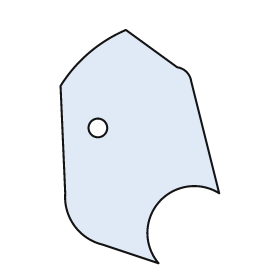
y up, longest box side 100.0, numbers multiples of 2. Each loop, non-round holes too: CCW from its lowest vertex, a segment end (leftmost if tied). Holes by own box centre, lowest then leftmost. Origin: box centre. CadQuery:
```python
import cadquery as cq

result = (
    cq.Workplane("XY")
    .moveTo(8.0, -50.0)
    .threePointArc((8.0, -24.0), (34.0, -20.0))
    .lineTo(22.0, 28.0)
    .threePointArc((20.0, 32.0), (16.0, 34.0))
    .lineTo(-6.0, 50.0)
    .threePointArc((-22.0, 40.0), (-34.0, 26.0))
    .lineTo(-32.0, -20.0)
    .threePointArc((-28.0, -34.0), (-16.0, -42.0))
    .close()
    .moveTo(-18.0, 8.0)
    .circle(4.0)
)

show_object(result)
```